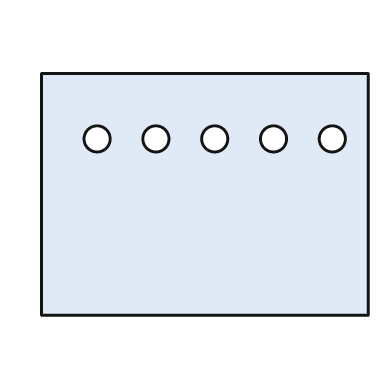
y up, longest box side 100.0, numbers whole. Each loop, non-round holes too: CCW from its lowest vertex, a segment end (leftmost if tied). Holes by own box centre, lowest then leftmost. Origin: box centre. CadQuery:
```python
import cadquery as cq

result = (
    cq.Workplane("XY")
    .moveTo(-50.0, -37.0)
    .lineTo(50.0, -37.0)
    .lineTo(50.0, 37.0)
    .lineTo(-50.0, 37.0)
    .close()
    .moveTo(-33.0, 17.0)
    .circle(4.0)
    .moveTo(-15.0, 17.0)
    .circle(4.0)
    .moveTo(3.0, 17.0)
    .circle(4.0)
    .moveTo(21.0, 17.0)
    .circle(4.0)
    .moveTo(39.0, 17.0)
    .circle(4.0)
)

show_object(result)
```